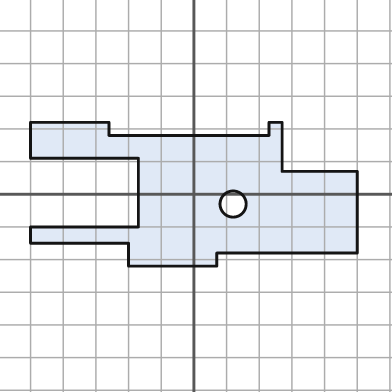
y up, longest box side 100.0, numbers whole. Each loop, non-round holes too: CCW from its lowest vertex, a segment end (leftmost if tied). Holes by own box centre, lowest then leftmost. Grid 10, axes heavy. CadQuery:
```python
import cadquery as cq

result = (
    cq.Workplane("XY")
    .moveTo(-20.0, -22.0)
    .lineTo(7.0, -22.0)
    .lineTo(7.0, -18.0)
    .lineTo(50.0, -18.0)
    .lineTo(50.0, 7.0)
    .lineTo(27.0, 7.0)
    .lineTo(27.0, 22.0)
    .lineTo(23.0, 22.0)
    .lineTo(23.0, 18.0)
    .lineTo(-26.0, 18.0)
    .lineTo(-26.0, 22.0)
    .lineTo(-50.0, 22.0)
    .lineTo(-50.0, 11.0)
    .lineTo(-17.0, 11.0)
    .lineTo(-17.0, -10.0)
    .lineTo(-50.0, -10.0)
    .lineTo(-50.0, -15.0)
    .lineTo(-20.0, -15.0)
    .close()
    .moveTo(12.0, -3.0)
    .circle(4.0)
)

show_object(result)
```